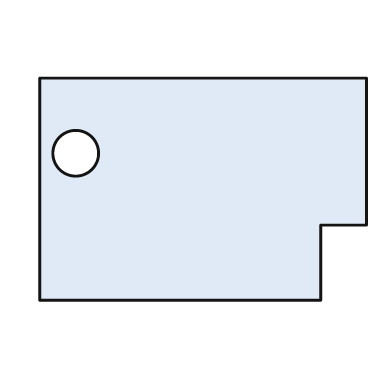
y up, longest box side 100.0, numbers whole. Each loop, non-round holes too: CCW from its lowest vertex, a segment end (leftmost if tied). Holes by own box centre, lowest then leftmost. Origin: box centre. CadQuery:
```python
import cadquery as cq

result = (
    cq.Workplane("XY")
    .moveTo(-50.0, -34.0)
    .lineTo(36.0, -34.0)
    .lineTo(36.0, -11.0)
    .lineTo(50.0, -11.0)
    .lineTo(50.0, 34.0)
    .lineTo(-50.0, 34.0)
    .close()
    .moveTo(-39.0, 11.0)
    .circle(7.0)
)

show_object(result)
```